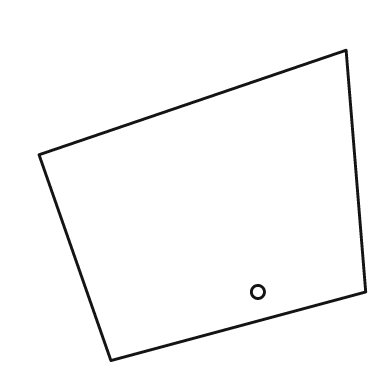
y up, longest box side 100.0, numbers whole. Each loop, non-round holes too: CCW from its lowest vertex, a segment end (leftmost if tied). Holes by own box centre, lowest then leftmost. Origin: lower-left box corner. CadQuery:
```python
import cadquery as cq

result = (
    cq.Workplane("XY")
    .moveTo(22.0, 0.0)
    .lineTo(100.0, 21.0)
    .lineTo(94.0, 95.0)
    .lineTo(0.0, 63.0)
    .close()
    .moveTo(67.0, 21.0)
    .circle(2.0)
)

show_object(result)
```